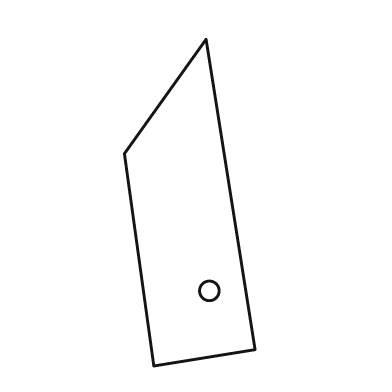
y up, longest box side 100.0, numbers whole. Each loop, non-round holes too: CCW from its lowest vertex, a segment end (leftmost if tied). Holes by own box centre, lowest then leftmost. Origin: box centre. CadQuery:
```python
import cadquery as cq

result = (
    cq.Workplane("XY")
    .moveTo(-11.0, -50.0)
    .lineTo(20.0, -45.0)
    .lineTo(5.0, 50.0)
    .lineTo(-20.0, 15.0)
    .close()
    .moveTo(6.0, -27.0)
    .circle(3.0)
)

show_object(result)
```